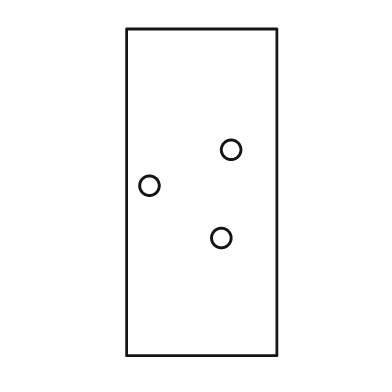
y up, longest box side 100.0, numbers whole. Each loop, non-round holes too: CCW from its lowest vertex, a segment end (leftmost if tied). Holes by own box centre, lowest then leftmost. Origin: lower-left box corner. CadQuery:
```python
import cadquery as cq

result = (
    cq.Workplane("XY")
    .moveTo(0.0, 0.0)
    .lineTo(46.0, 0.0)
    .lineTo(46.0, 100.0)
    .lineTo(0.0, 100.0)
    .close()
    .moveTo(29.0, 36.0)
    .circle(3.0)
    .moveTo(7.0, 52.0)
    .circle(3.0)
    .moveTo(32.0, 63.0)
    .circle(3.0)
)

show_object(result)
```